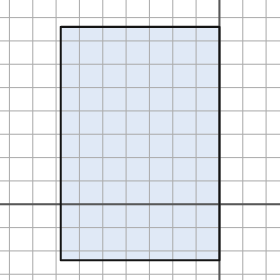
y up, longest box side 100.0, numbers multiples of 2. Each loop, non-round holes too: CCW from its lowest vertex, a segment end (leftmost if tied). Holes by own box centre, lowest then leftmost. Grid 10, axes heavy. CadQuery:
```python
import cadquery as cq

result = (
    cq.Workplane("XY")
    .moveTo(-68.0, -24.0)
    .lineTo(0.0, -24.0)
    .lineTo(0.0, 76.0)
    .lineTo(-68.0, 76.0)
    .close()
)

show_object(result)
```